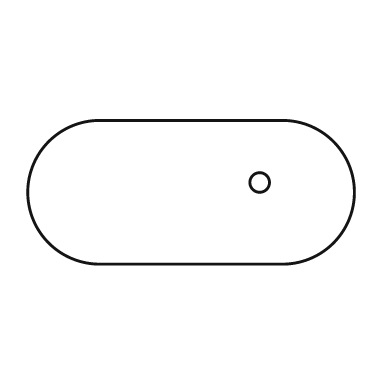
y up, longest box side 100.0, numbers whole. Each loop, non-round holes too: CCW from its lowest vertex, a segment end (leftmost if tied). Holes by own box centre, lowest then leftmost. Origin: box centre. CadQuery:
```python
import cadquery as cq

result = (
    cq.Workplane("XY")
    .moveTo(-28.0, -22.0)
    .lineTo(28.0, -22.0)
    .threePointArc((50.0, 0.0), (28.0, 22.0))
    .lineTo(-28.0, 22.0)
    .threePointArc((-50.0, 0.0), (-28.0, -22.0))
    .close()
    .moveTo(21.0, 3.0)
    .circle(3.0)
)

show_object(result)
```